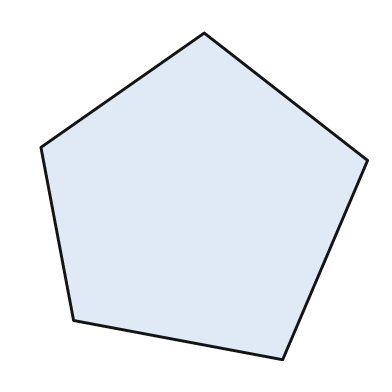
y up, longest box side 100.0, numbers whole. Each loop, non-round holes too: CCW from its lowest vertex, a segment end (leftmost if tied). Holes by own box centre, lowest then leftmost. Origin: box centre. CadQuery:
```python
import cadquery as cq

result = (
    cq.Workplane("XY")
    .moveTo(24.0, -50.0)
    .lineTo(50.0, 11.0)
    .lineTo(0.0, 50.0)
    .lineTo(-50.0, 15.0)
    .lineTo(-40.0, -38.0)
    .close()
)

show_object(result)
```